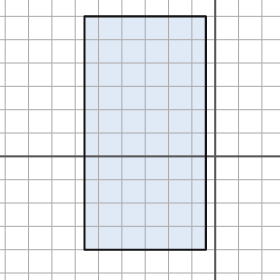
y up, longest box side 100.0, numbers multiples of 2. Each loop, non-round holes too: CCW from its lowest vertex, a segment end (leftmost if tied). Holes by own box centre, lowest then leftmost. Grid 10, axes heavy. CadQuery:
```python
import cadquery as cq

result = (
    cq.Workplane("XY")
    .moveTo(-56.0, -40.0)
    .lineTo(-4.0, -40.0)
    .lineTo(-4.0, 60.0)
    .lineTo(-56.0, 60.0)
    .close()
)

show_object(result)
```